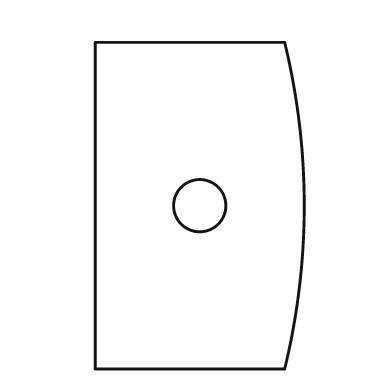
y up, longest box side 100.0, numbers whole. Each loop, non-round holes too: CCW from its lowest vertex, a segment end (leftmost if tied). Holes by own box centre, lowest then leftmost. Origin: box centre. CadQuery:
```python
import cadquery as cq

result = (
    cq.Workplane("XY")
    .moveTo(-32.0, -50.0)
    .lineTo(26.0, -50.0)
    .threePointArc((32.0, 0.0), (26.0, 50.0))
    .lineTo(-32.0, 50.0)
    .close()
    .moveTo(0.0, 0.0)
    .circle(8.0)
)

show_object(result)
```